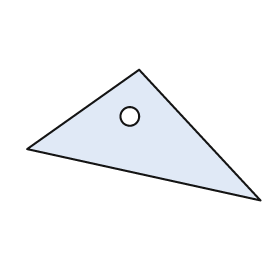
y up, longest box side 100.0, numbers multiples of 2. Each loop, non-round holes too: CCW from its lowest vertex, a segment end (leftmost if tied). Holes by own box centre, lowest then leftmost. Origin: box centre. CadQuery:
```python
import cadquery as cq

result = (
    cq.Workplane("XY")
    .moveTo(50.0, -28.0)
    .lineTo(-2.0, 28.0)
    .lineTo(-50.0, -6.0)
    .close()
    .moveTo(-6.0, 8.0)
    .circle(4.0)
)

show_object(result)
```